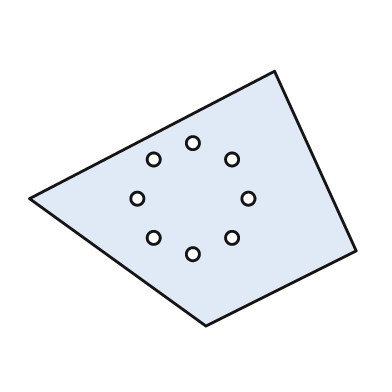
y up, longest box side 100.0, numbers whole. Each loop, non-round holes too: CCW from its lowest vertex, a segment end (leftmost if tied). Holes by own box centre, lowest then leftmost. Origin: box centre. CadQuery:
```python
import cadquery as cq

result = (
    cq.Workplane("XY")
    .moveTo(4.0, -39.0)
    .lineTo(50.0, -16.0)
    .lineTo(25.0, 39.0)
    .lineTo(-50.0, 0.0)
    .close()
    .moveTo(0.0, -17.0)
    .circle(2.0)
    .moveTo(-12.0, -12.0)
    .circle(2.0)
    .moveTo(12.0, -12.0)
    .circle(2.0)
    .moveTo(-17.0, 0.0)
    .circle(2.0)
    .moveTo(17.0, 0.0)
    .circle(2.0)
    .moveTo(-12.0, 12.0)
    .circle(2.0)
    .moveTo(12.0, 12.0)
    .circle(2.0)
    .moveTo(0.0, 17.0)
    .circle(2.0)
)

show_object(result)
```